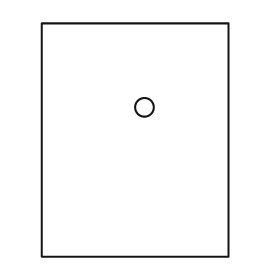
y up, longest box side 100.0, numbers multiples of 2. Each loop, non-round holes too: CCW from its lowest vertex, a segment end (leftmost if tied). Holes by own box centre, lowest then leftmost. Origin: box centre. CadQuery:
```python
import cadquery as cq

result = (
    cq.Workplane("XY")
    .moveTo(-40.0, -50.0)
    .lineTo(40.0, -50.0)
    .lineTo(40.0, 50.0)
    .lineTo(-40.0, 50.0)
    .close()
    .moveTo(4.0, 14.0)
    .circle(4.0)
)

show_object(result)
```